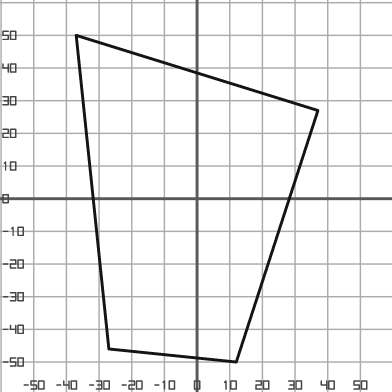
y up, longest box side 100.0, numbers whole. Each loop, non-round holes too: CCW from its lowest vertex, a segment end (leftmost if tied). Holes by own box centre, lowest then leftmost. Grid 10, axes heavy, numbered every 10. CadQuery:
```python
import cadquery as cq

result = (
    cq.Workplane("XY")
    .moveTo(12.0, -50.0)
    .lineTo(37.0, 27.0)
    .lineTo(-37.0, 50.0)
    .lineTo(-27.0, -46.0)
    .close()
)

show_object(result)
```